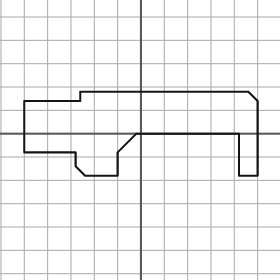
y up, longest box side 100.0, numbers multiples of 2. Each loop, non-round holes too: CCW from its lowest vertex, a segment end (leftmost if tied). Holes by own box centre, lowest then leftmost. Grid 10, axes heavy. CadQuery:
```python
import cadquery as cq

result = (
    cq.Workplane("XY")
    .moveTo(-24.0, -18.0)
    .lineTo(-10.0, -18.0)
    .lineTo(-10.0, -8.0)
    .lineTo(-2.0, 0.0)
    .lineTo(42.0, 0.0)
    .lineTo(42.0, -18.0)
    .lineTo(50.0, -18.0)
    .lineTo(50.0, 14.0)
    .lineTo(46.0, 18.0)
    .lineTo(-26.0, 18.0)
    .lineTo(-26.0, 14.0)
    .lineTo(-50.0, 14.0)
    .lineTo(-50.0, -8.0)
    .lineTo(-28.0, -8.0)
    .lineTo(-28.0, -14.0)
    .close()
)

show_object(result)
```